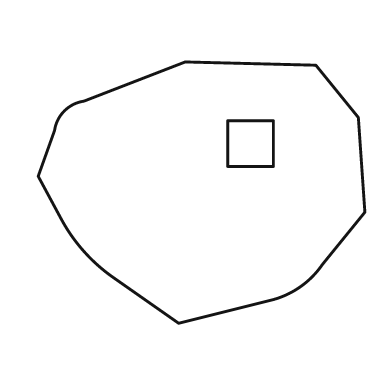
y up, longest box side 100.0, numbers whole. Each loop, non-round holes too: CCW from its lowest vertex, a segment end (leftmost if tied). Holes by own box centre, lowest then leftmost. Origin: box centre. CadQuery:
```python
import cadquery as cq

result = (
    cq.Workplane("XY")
    .moveTo(-7.0, -40.0)
    .lineTo(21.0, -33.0)
    .threePointArc((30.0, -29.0), (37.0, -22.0))
    .lineTo(50.0, -6.0)
    .lineTo(48.0, 23.0)
    .lineTo(35.0, 39.0)
    .lineTo(-5.0, 40.0)
    .lineTo(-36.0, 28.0)
    .threePointArc((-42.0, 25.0), (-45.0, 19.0))
    .lineTo(-50.0, 5.0)
    .lineTo(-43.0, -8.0)
    .threePointArc((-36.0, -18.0), (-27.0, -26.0))
    .close()
    .moveTo(8.0, 8.0)
    .lineTo(22.0, 8.0)
    .lineTo(22.0, 22.0)
    .lineTo(8.0, 22.0)
    .close()
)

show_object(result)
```